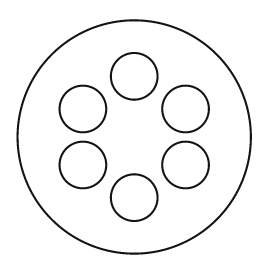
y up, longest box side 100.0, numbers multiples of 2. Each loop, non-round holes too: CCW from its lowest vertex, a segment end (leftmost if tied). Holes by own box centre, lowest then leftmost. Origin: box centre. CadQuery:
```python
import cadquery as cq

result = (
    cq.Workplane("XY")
    .moveTo(0.0, 0.0)
    .circle(50.0)
    .moveTo(0.0, -26.0)
    .circle(10.0)
    .moveTo(-22.0, -12.0)
    .circle(10.0)
    .moveTo(22.0, -12.0)
    .circle(10.0)
    .moveTo(-22.0, 12.0)
    .circle(10.0)
    .moveTo(22.0, 12.0)
    .circle(10.0)
    .moveTo(0.0, 26.0)
    .circle(10.0)
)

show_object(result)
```